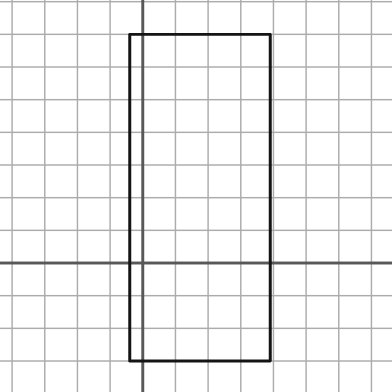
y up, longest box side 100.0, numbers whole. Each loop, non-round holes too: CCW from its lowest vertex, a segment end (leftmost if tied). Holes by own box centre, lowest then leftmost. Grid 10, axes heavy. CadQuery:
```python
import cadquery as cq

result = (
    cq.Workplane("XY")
    .moveTo(-4.0, -30.0)
    .lineTo(39.0, -30.0)
    .lineTo(39.0, 70.0)
    .lineTo(-4.0, 70.0)
    .close()
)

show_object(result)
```